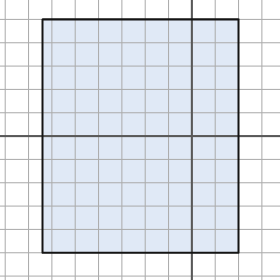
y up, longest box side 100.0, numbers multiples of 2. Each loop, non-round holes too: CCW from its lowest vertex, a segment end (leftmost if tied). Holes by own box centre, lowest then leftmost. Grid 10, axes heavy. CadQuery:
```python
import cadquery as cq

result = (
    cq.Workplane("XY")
    .moveTo(-64.0, -50.0)
    .lineTo(20.0, -50.0)
    .lineTo(20.0, 50.0)
    .lineTo(-64.0, 50.0)
    .close()
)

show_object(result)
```